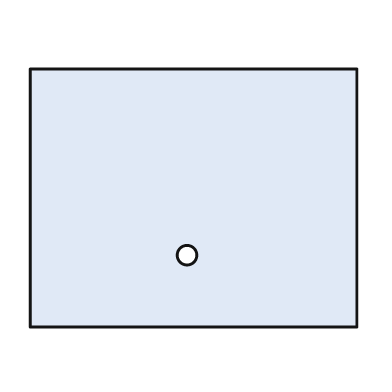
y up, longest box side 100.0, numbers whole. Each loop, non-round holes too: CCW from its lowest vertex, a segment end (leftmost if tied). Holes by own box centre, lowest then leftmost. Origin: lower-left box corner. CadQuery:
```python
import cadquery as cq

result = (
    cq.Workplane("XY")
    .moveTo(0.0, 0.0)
    .lineTo(100.0, 0.0)
    .lineTo(100.0, 79.0)
    .lineTo(0.0, 79.0)
    .close()
    .moveTo(48.0, 22.0)
    .circle(3.0)
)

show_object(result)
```